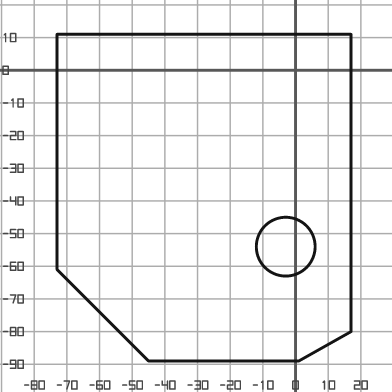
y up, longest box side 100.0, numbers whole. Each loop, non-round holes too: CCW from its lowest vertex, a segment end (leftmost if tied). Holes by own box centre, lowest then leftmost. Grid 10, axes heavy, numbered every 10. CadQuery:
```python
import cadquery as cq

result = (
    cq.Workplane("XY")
    .moveTo(-45.0, -89.0)
    .lineTo(1.0, -89.0)
    .lineTo(17.0, -80.0)
    .lineTo(17.0, 11.0)
    .lineTo(-73.0, 11.0)
    .lineTo(-73.0, -61.0)
    .close()
    .moveTo(-3.0, -54.0)
    .circle(9.0)
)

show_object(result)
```